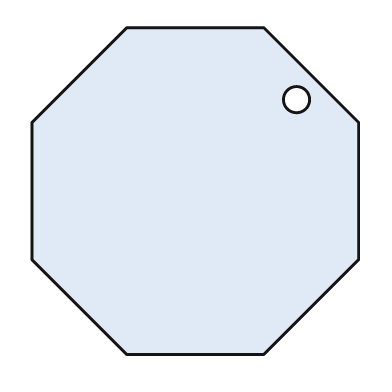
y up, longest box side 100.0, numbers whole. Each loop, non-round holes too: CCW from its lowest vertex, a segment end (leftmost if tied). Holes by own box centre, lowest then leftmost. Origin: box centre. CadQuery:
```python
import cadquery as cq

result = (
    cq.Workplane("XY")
    .moveTo(-21.0, -50.0)
    .lineTo(21.0, -50.0)
    .lineTo(50.0, -21.0)
    .lineTo(50.0, 21.0)
    .lineTo(21.0, 50.0)
    .lineTo(-21.0, 50.0)
    .lineTo(-50.0, 21.0)
    .lineTo(-50.0, -21.0)
    .close()
    .moveTo(31.0, 28.0)
    .circle(4.0)
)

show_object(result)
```